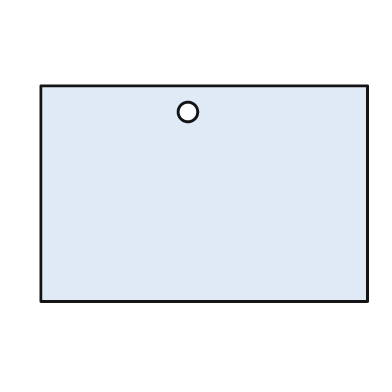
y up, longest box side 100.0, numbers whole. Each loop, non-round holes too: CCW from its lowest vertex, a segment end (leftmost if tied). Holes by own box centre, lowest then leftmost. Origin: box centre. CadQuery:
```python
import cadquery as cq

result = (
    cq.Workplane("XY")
    .moveTo(-50.0, -33.0)
    .lineTo(50.0, -33.0)
    .lineTo(50.0, 33.0)
    .lineTo(-50.0, 33.0)
    .close()
    .moveTo(-5.0, 25.0)
    .circle(3.0)
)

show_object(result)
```